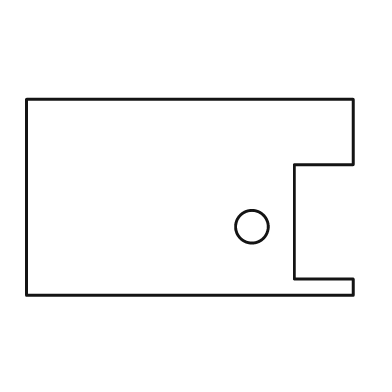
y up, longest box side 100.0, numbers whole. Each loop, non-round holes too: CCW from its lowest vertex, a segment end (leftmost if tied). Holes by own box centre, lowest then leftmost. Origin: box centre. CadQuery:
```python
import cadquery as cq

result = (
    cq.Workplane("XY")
    .moveTo(-50.0, -30.0)
    .lineTo(50.0, -30.0)
    .lineTo(50.0, -25.0)
    .lineTo(32.0, -25.0)
    .lineTo(32.0, 10.0)
    .lineTo(50.0, 10.0)
    .lineTo(50.0, 30.0)
    .lineTo(-50.0, 30.0)
    .close()
    .moveTo(19.0, -9.0)
    .circle(5.0)
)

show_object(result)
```